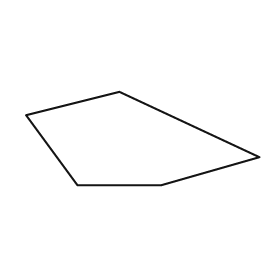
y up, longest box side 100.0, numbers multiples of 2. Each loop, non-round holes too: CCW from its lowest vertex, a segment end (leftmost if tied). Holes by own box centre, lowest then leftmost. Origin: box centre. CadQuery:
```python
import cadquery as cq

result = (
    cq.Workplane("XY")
    .moveTo(-28.0, -20.0)
    .lineTo(8.0, -20.0)
    .lineTo(50.0, -8.0)
    .lineTo(-10.0, 20.0)
    .lineTo(-50.0, 10.0)
    .close()
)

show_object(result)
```